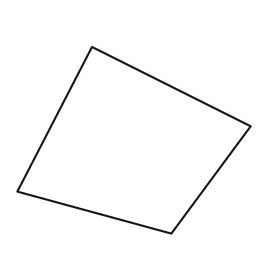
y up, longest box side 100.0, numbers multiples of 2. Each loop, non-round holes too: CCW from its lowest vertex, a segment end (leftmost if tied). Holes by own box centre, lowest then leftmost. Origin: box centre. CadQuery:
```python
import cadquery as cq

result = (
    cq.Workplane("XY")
    .moveTo(16.0, -40.0)
    .lineTo(50.0, 6.0)
    .lineTo(-18.0, 40.0)
    .lineTo(-50.0, -22.0)
    .close()
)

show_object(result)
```